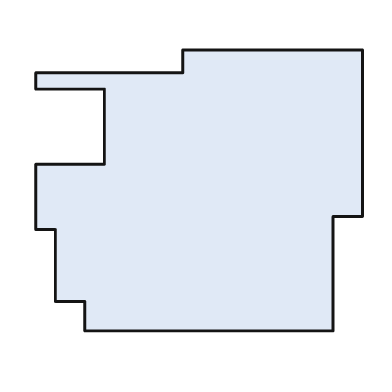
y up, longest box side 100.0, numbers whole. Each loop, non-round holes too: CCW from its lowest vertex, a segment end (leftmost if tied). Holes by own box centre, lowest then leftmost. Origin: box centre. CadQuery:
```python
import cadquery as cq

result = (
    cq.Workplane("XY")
    .moveTo(-35.0, -43.0)
    .lineTo(41.0, -43.0)
    .lineTo(41.0, -8.0)
    .lineTo(50.0, -8.0)
    .lineTo(50.0, 43.0)
    .lineTo(-5.0, 43.0)
    .lineTo(-5.0, 36.0)
    .lineTo(-50.0, 36.0)
    .lineTo(-50.0, 31.0)
    .lineTo(-29.0, 31.0)
    .lineTo(-29.0, 8.0)
    .lineTo(-50.0, 8.0)
    .lineTo(-50.0, -12.0)
    .lineTo(-44.0, -12.0)
    .lineTo(-44.0, -34.0)
    .lineTo(-35.0, -34.0)
    .close()
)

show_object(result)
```